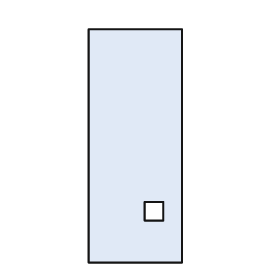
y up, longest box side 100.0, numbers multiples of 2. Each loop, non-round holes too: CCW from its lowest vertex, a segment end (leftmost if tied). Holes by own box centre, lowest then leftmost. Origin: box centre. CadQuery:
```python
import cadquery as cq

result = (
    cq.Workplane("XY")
    .moveTo(-20.0, -50.0)
    .lineTo(20.0, -50.0)
    .lineTo(20.0, 50.0)
    .lineTo(-20.0, 50.0)
    .close()
    .moveTo(4.0, -32.0)
    .lineTo(12.0, -32.0)
    .lineTo(12.0, -24.0)
    .lineTo(4.0, -24.0)
    .close()
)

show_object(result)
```